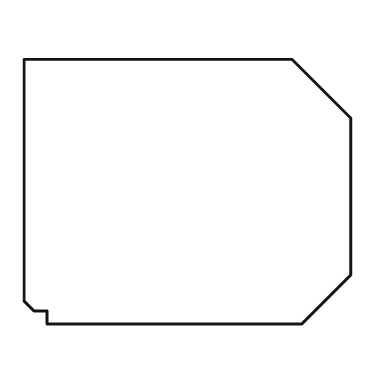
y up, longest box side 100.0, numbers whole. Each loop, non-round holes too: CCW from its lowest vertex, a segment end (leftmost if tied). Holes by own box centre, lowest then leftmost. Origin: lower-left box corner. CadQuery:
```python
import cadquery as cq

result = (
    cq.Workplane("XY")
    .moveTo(7.0, 0.0)
    .lineTo(85.0, 0.0)
    .lineTo(100.0, 15.0)
    .lineTo(100.0, 63.0)
    .lineTo(82.0, 81.0)
    .lineTo(0.0, 81.0)
    .lineTo(0.0, 7.0)
    .lineTo(3.0, 4.0)
    .lineTo(7.0, 4.0)
    .close()
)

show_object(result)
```